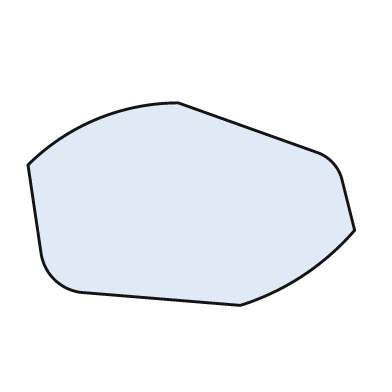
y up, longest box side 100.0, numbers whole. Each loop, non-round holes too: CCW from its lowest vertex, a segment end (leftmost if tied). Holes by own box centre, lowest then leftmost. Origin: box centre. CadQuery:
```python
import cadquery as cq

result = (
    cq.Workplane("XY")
    .moveTo(15.0, -31.0)
    .threePointArc((34.0, -22.0), (50.0, -8.0))
    .lineTo(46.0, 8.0)
    .threePointArc((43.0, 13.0), (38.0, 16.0))
    .lineTo(-4.0, 31.0)
    .threePointArc((-29.0, 26.0), (-50.0, 12.0))
    .lineTo(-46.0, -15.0)
    .threePointArc((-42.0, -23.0), (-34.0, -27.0))
    .close()
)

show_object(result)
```